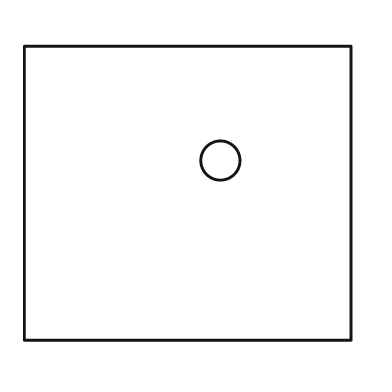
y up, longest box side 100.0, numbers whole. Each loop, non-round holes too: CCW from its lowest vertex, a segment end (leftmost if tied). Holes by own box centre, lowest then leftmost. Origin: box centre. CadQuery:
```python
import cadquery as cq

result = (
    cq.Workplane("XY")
    .moveTo(-50.0, -45.0)
    .lineTo(50.0, -45.0)
    .lineTo(50.0, 45.0)
    .lineTo(-50.0, 45.0)
    .close()
    .moveTo(10.0, 10.0)
    .circle(6.0)
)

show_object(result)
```